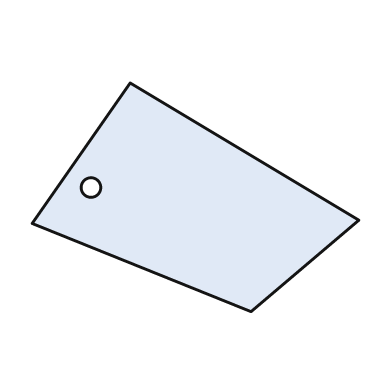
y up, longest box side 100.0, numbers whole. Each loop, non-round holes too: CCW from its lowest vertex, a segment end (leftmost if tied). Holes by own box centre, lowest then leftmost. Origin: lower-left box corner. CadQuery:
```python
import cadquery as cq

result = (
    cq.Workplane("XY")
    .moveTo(67.0, 0.0)
    .lineTo(100.0, 28.0)
    .lineTo(30.0, 70.0)
    .lineTo(0.0, 27.0)
    .close()
    .moveTo(18.0, 38.0)
    .circle(3.0)
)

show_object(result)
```